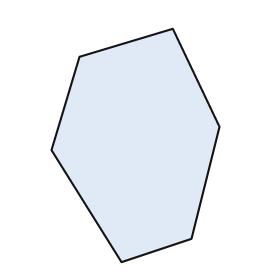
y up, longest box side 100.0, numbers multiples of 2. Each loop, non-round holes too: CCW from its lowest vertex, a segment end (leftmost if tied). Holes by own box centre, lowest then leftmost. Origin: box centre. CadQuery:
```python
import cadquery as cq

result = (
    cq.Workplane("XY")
    .moveTo(-6.0, -50.0)
    .lineTo(24.0, -40.0)
    .lineTo(36.0, 8.0)
    .lineTo(16.0, 50.0)
    .lineTo(-24.0, 38.0)
    .lineTo(-36.0, -2.0)
    .close()
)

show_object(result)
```